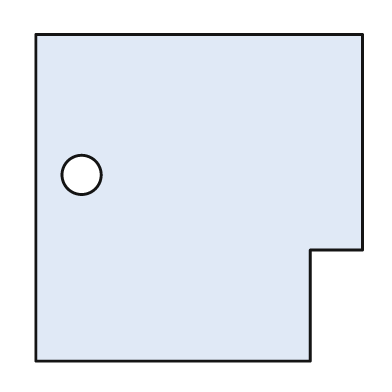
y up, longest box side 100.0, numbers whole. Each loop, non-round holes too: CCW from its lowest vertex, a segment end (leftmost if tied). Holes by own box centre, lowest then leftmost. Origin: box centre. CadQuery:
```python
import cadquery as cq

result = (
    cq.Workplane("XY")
    .moveTo(-50.0, -50.0)
    .lineTo(34.0, -50.0)
    .lineTo(34.0, -16.0)
    .lineTo(50.0, -16.0)
    .lineTo(50.0, 50.0)
    .lineTo(-50.0, 50.0)
    .close()
    .moveTo(-36.0, 7.0)
    .circle(6.0)
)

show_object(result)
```